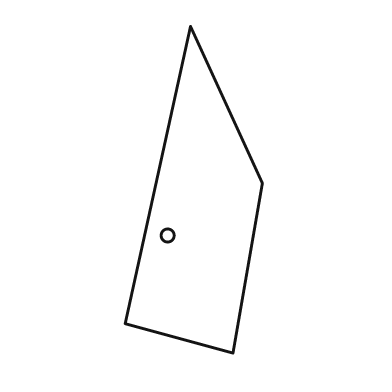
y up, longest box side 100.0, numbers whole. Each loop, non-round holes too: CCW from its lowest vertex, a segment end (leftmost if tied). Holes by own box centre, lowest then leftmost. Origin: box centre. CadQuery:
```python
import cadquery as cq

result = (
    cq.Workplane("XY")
    .moveTo(12.0, -50.0)
    .lineTo(21.0, 2.0)
    .lineTo(-1.0, 50.0)
    .lineTo(-21.0, -41.0)
    .close()
    .moveTo(-8.0, -14.0)
    .circle(2.0)
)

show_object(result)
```